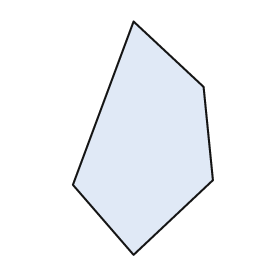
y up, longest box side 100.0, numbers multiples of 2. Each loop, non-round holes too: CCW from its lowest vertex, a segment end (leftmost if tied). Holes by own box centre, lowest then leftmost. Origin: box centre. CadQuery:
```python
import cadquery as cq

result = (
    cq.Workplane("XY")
    .moveTo(-4.0, -50.0)
    .lineTo(30.0, -18.0)
    .lineTo(26.0, 22.0)
    .lineTo(-4.0, 50.0)
    .lineTo(-30.0, -20.0)
    .close()
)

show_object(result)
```